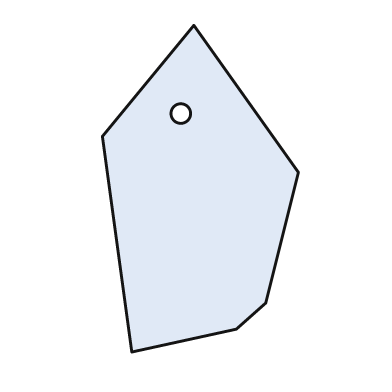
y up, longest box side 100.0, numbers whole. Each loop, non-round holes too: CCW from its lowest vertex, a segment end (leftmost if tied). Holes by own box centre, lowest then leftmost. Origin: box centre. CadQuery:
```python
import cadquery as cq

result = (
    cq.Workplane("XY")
    .moveTo(-21.0, -50.0)
    .lineTo(11.0, -43.0)
    .lineTo(20.0, -35.0)
    .lineTo(30.0, 5.0)
    .lineTo(-2.0, 50.0)
    .lineTo(-30.0, 16.0)
    .close()
    .moveTo(-6.0, 23.0)
    .circle(3.0)
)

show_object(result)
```